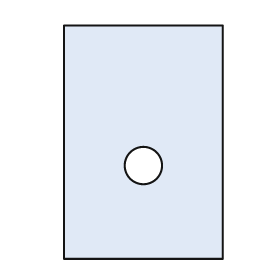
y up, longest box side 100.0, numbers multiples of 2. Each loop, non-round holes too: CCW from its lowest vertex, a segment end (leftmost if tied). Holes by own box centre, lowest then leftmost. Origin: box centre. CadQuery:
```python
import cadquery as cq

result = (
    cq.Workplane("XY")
    .moveTo(-34.0, -50.0)
    .lineTo(34.0, -50.0)
    .lineTo(34.0, 50.0)
    .lineTo(-34.0, 50.0)
    .close()
    .moveTo(0.0, -10.0)
    .circle(8.0)
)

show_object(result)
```